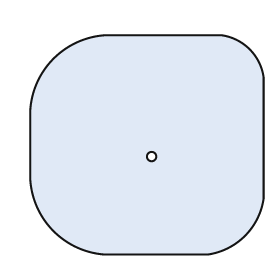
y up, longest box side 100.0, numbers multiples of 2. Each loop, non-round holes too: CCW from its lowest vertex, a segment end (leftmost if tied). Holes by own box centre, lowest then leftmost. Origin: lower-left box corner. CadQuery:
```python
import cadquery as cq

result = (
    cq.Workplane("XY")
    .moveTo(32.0, 0.0)
    .lineTo(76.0, 0.0)
    .threePointArc((92.0, 8.0), (100.0, 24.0))
    .lineTo(100.0, 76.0)
    .threePointArc((94.0, 88.0), (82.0, 94.0))
    .lineTo(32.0, 94.0)
    .threePointArc((10.0, 84.0), (0.0, 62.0))
    .lineTo(0.0, 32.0)
    .threePointArc((10.0, 10.0), (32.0, 0.0))
    .close()
    .moveTo(52.0, 42.0)
    .circle(2.0)
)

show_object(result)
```